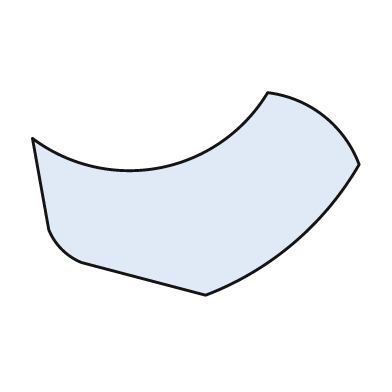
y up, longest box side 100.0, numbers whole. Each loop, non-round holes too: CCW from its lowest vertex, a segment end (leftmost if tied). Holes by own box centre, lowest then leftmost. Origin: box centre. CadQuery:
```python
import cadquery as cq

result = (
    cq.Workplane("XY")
    .moveTo(3.0, -31.0)
    .threePointArc((30.0, -15.0), (50.0, 9.0))
    .threePointArc((39.0, 24.0), (22.0, 31.0))
    .threePointArc((-11.0, 8.0), (-50.0, 17.0))
    .lineTo(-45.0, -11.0)
    .threePointArc((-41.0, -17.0), (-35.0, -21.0))
    .close()
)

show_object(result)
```